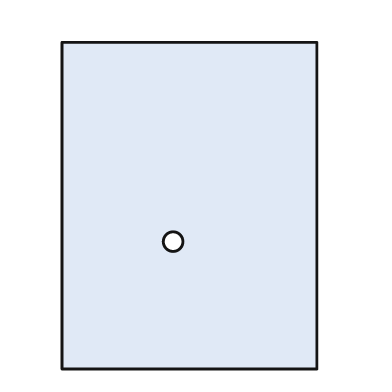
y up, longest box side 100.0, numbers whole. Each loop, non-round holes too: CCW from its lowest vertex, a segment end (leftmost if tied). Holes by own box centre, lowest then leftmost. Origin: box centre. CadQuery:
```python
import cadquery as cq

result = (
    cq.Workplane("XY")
    .moveTo(-39.0, -50.0)
    .lineTo(39.0, -50.0)
    .lineTo(39.0, 50.0)
    .lineTo(-39.0, 50.0)
    .close()
    .moveTo(-5.0, -11.0)
    .circle(3.0)
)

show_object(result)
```